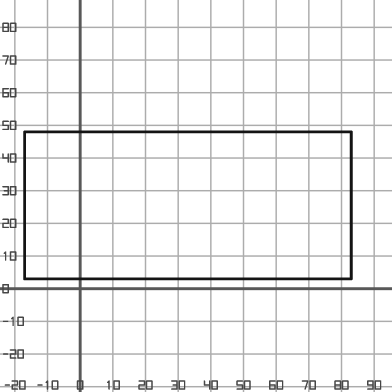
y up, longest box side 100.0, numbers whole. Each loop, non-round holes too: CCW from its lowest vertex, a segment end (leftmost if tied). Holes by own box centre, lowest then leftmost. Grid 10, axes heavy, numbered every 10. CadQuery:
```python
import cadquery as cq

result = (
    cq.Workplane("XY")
    .moveTo(-17.0, 3.0)
    .lineTo(83.0, 3.0)
    .lineTo(83.0, 48.0)
    .lineTo(-17.0, 48.0)
    .close()
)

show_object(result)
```